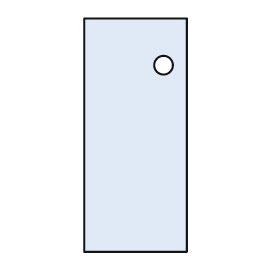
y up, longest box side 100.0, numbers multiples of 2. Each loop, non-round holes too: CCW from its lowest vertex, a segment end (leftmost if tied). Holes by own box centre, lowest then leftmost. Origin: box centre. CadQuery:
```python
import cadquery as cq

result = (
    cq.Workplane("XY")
    .moveTo(-22.0, -50.0)
    .lineTo(22.0, -50.0)
    .lineTo(22.0, 50.0)
    .lineTo(-22.0, 50.0)
    .close()
    .moveTo(12.0, 30.0)
    .circle(4.0)
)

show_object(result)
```